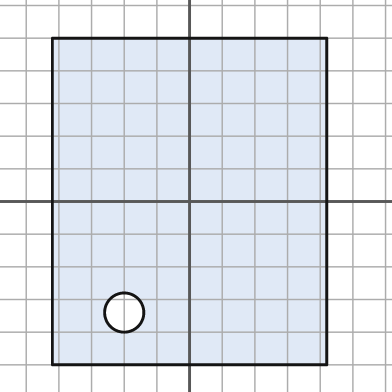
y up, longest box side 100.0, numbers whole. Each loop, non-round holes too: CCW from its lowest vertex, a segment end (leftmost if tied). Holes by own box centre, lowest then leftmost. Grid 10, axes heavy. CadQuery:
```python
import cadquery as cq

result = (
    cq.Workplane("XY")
    .moveTo(-42.0, -50.0)
    .lineTo(42.0, -50.0)
    .lineTo(42.0, 50.0)
    .lineTo(-42.0, 50.0)
    .close()
    .moveTo(-20.0, -34.0)
    .circle(6.0)
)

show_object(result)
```